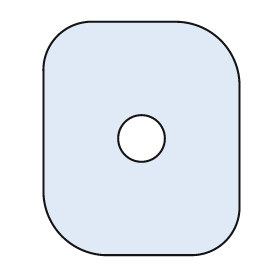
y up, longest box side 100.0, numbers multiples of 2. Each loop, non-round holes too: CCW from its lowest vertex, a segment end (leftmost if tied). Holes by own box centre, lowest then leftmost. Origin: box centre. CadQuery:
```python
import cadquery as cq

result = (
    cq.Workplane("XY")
    .moveTo(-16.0, -50.0)
    .lineTo(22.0, -50.0)
    .threePointArc((36.0, -44.0), (42.0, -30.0))
    .lineTo(42.0, 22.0)
    .threePointArc((34.0, 42.0), (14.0, 50.0))
    .lineTo(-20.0, 50.0)
    .threePointArc((-36.0, 44.0), (-42.0, 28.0))
    .lineTo(-42.0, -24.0)
    .threePointArc((-34.0, -42.0), (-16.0, -50.0))
    .close()
    .moveTo(0.0, 0.0)
    .circle(10.0)
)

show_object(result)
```